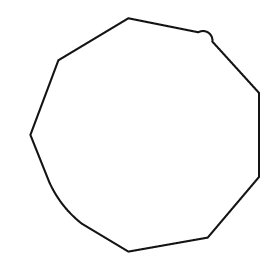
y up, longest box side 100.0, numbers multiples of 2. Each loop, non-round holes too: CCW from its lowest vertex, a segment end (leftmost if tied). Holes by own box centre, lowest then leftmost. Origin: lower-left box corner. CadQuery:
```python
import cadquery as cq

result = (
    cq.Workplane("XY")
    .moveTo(42.0, 0.0)
    .lineTo(76.0, 6.0)
    .lineTo(98.0, 32.0)
    .lineTo(98.0, 68.0)
    .lineTo(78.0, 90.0)
    .threePointArc((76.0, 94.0), (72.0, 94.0))
    .lineTo(42.0, 100.0)
    .lineTo(12.0, 82.0)
    .lineTo(0.0, 50.0)
    .lineTo(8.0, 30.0)
    .threePointArc((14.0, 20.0), (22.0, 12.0))
    .close()
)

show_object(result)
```